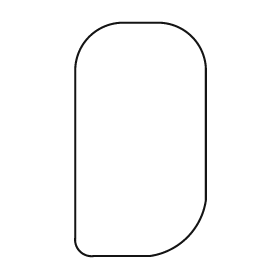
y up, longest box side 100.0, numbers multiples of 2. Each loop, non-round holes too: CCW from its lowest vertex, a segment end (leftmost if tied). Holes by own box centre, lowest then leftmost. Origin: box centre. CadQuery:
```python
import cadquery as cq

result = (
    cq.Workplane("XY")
    .moveTo(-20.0, -50.0)
    .lineTo(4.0, -50.0)
    .threePointArc((20.0, -42.0), (28.0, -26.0))
    .lineTo(28.0, 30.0)
    .threePointArc((22.0, 44.0), (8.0, 50.0))
    .lineTo(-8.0, 50.0)
    .threePointArc((-22.0, 44.0), (-28.0, 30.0))
    .lineTo(-28.0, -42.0)
    .threePointArc((-26.0, -48.0), (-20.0, -50.0))
    .close()
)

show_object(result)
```